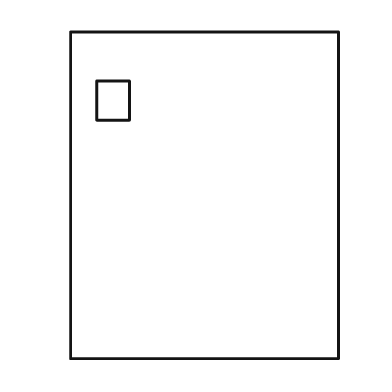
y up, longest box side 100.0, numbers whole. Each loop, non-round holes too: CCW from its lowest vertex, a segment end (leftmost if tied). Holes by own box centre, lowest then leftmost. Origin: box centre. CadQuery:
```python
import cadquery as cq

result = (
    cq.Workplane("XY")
    .moveTo(-41.0, -50.0)
    .lineTo(41.0, -50.0)
    .lineTo(41.0, 50.0)
    .lineTo(-41.0, 50.0)
    .close()
    .moveTo(-33.0, 23.0)
    .lineTo(-23.0, 23.0)
    .lineTo(-23.0, 35.0)
    .lineTo(-33.0, 35.0)
    .close()
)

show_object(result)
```